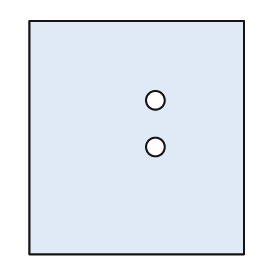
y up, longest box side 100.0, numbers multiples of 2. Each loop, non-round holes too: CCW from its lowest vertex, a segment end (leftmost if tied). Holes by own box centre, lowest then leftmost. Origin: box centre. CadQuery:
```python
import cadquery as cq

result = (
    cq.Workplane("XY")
    .moveTo(-46.0, -50.0)
    .lineTo(46.0, -50.0)
    .lineTo(46.0, 50.0)
    .lineTo(-46.0, 50.0)
    .close()
    .moveTo(8.0, -4.0)
    .circle(4.0)
    .moveTo(8.0, 16.0)
    .circle(4.0)
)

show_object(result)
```